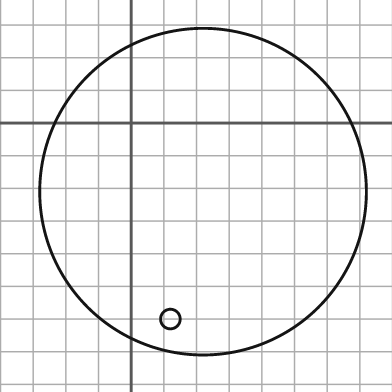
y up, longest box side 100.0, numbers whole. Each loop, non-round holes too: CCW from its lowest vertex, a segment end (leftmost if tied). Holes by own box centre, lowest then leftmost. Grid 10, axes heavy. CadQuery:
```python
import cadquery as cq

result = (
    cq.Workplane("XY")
    .moveTo(22.0, -21.0)
    .circle(50.0)
    .moveTo(12.0, -60.0)
    .circle(3.0)
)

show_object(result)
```